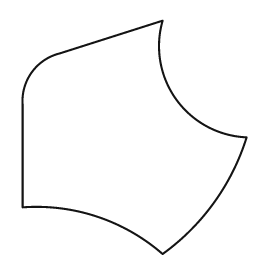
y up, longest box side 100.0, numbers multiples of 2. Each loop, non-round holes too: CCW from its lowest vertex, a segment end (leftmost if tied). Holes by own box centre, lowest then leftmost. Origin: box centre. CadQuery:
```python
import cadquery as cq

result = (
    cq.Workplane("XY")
    .moveTo(12.0, -50.0)
    .threePointArc((34.0, -28.0), (48.0, 0.0))
    .threePointArc((18.0, 16.0), (12.0, 50.0))
    .lineTo(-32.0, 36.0)
    .threePointArc((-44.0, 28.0), (-48.0, 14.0))
    .lineTo(-48.0, -30.0)
    .threePointArc((-16.0, -34.0), (12.0, -50.0))
    .close()
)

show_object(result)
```